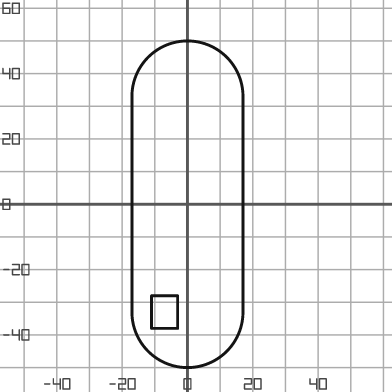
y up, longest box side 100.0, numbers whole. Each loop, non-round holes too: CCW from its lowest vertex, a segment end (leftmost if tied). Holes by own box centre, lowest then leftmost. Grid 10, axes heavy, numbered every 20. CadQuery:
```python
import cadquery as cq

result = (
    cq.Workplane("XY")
    .moveTo(-17.0, -33.0)
    .threePointArc((0.0, -50.0), (17.0, -33.0))
    .lineTo(17.0, 33.0)
    .threePointArc((0.0, 50.0), (-17.0, 33.0))
    .close()
    .moveTo(-11.0, -38.0)
    .lineTo(-3.0, -38.0)
    .lineTo(-3.0, -28.0)
    .lineTo(-11.0, -28.0)
    .close()
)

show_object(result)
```